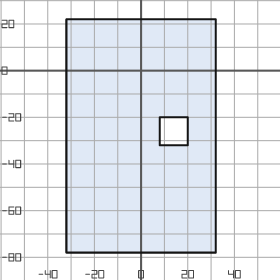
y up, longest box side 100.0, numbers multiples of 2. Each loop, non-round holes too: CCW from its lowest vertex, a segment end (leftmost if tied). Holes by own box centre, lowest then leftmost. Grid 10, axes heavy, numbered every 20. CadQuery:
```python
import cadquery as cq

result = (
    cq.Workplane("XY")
    .moveTo(-32.0, -78.0)
    .lineTo(32.0, -78.0)
    .lineTo(32.0, 22.0)
    .lineTo(-32.0, 22.0)
    .close()
    .moveTo(8.0, -32.0)
    .lineTo(20.0, -32.0)
    .lineTo(20.0, -20.0)
    .lineTo(8.0, -20.0)
    .close()
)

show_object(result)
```